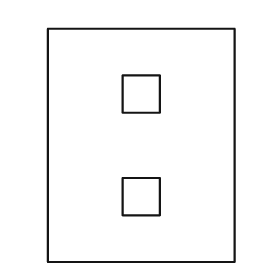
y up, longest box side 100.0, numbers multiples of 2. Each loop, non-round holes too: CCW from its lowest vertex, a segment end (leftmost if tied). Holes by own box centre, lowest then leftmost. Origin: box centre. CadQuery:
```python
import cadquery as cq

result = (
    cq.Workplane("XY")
    .moveTo(-40.0, -50.0)
    .lineTo(40.0, -50.0)
    .lineTo(40.0, 50.0)
    .lineTo(-40.0, 50.0)
    .close()
    .moveTo(-8.0, -30.0)
    .lineTo(8.0, -30.0)
    .lineTo(8.0, -14.0)
    .lineTo(-8.0, -14.0)
    .close()
    .moveTo(-8.0, 14.0)
    .lineTo(8.0, 14.0)
    .lineTo(8.0, 30.0)
    .lineTo(-8.0, 30.0)
    .close()
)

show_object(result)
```